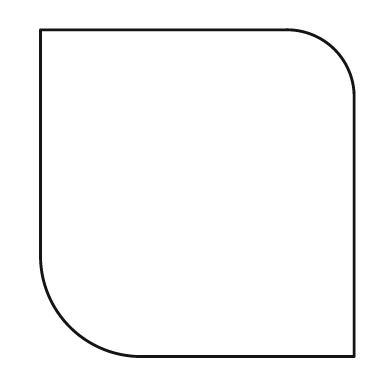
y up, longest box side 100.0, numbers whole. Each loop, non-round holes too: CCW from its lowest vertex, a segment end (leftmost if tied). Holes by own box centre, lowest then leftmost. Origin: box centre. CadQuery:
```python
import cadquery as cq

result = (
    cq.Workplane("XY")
    .moveTo(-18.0, -50.0)
    .lineTo(48.0, -50.0)
    .lineTo(48.0, 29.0)
    .threePointArc((42.0, 44.0), (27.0, 50.0))
    .lineTo(-48.0, 50.0)
    .lineTo(-48.0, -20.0)
    .threePointArc((-39.0, -41.0), (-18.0, -50.0))
    .close()
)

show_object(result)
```